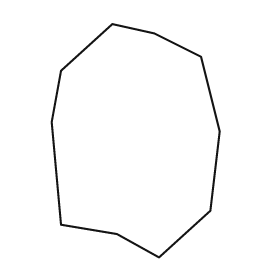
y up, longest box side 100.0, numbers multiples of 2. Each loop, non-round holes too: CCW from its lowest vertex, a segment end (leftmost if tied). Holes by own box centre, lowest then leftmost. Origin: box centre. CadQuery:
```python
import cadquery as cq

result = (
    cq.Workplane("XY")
    .moveTo(10.0, -50.0)
    .lineTo(32.0, -30.0)
    .lineTo(36.0, 4.0)
    .lineTo(28.0, 36.0)
    .lineTo(8.0, 46.0)
    .lineTo(-10.0, 50.0)
    .lineTo(-32.0, 30.0)
    .lineTo(-36.0, 8.0)
    .lineTo(-32.0, -36.0)
    .lineTo(-8.0, -40.0)
    .close()
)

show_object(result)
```